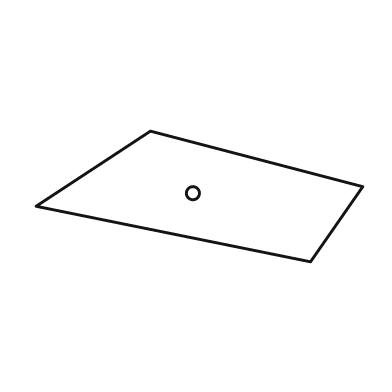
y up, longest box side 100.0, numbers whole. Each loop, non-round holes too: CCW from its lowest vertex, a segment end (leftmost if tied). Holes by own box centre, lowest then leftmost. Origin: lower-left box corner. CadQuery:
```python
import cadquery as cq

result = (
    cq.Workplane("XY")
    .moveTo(84.0, 0.0)
    .lineTo(100.0, 23.0)
    .lineTo(35.0, 40.0)
    .lineTo(0.0, 17.0)
    .close()
    .moveTo(48.0, 21.0)
    .circle(2.0)
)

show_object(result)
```